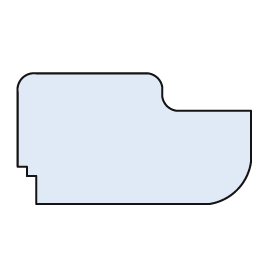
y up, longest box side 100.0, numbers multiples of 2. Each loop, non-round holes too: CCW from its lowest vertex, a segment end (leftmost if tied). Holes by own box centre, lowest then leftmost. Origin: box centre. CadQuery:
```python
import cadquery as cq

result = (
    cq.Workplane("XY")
    .moveTo(-42.0, -28.0)
    .lineTo(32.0, -28.0)
    .threePointArc((44.0, -22.0), (50.0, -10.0))
    .lineTo(50.0, 12.0)
    .lineTo(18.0, 12.0)
    .threePointArc((14.0, 14.0), (12.0, 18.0))
    .lineTo(12.0, 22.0)
    .threePointArc((10.0, 26.0), (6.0, 28.0))
    .lineTo(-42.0, 28.0)
    .threePointArc((-48.0, 26.0), (-50.0, 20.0))
    .lineTo(-50.0, -12.0)
    .lineTo(-46.0, -12.0)
    .lineTo(-46.0, -16.0)
    .lineTo(-42.0, -16.0)
    .close()
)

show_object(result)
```